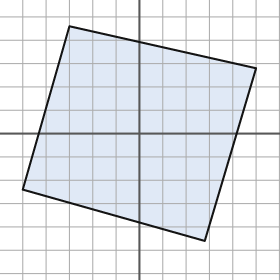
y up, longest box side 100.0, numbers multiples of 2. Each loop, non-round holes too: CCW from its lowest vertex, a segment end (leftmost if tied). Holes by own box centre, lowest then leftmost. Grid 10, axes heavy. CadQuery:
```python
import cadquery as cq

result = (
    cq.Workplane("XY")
    .moveTo(28.0, -46.0)
    .lineTo(50.0, 28.0)
    .lineTo(-30.0, 46.0)
    .lineTo(-50.0, -24.0)
    .close()
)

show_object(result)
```